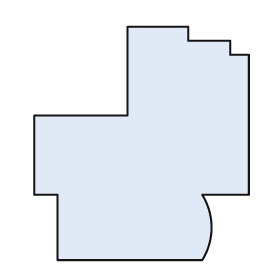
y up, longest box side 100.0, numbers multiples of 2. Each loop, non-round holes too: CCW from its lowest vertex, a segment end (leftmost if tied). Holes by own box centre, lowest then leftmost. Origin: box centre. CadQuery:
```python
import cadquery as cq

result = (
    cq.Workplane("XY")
    .moveTo(-36.0, -50.0)
    .lineTo(26.0, -50.0)
    .threePointArc((30.0, -36.0), (26.0, -22.0))
    .lineTo(46.0, -22.0)
    .lineTo(46.0, 38.0)
    .lineTo(38.0, 38.0)
    .lineTo(38.0, 44.0)
    .lineTo(20.0, 44.0)
    .lineTo(20.0, 50.0)
    .lineTo(-6.0, 50.0)
    .lineTo(-6.0, 12.0)
    .lineTo(-46.0, 12.0)
    .lineTo(-46.0, -22.0)
    .lineTo(-36.0, -22.0)
    .close()
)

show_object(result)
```